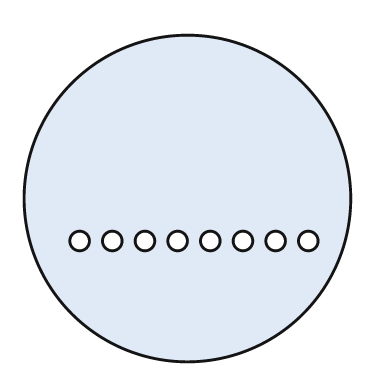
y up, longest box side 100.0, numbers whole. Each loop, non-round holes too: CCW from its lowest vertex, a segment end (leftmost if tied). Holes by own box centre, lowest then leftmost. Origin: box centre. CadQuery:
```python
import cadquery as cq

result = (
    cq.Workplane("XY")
    .moveTo(0.0, 0.0)
    .circle(50.0)
    .moveTo(-33.0, -13.0)
    .circle(3.0)
    .moveTo(-23.0, -13.0)
    .circle(3.0)
    .moveTo(-13.0, -13.0)
    .circle(3.0)
    .moveTo(-3.0, -13.0)
    .circle(3.0)
    .moveTo(7.0, -13.0)
    .circle(3.0)
    .moveTo(17.0, -13.0)
    .circle(3.0)
    .moveTo(27.0, -13.0)
    .circle(3.0)
    .moveTo(37.0, -13.0)
    .circle(3.0)
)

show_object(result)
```